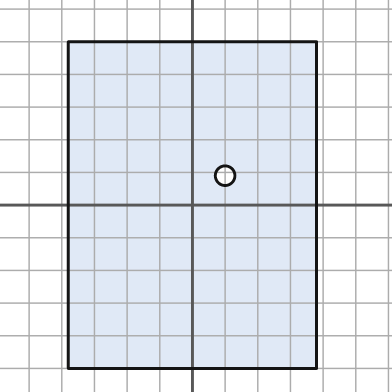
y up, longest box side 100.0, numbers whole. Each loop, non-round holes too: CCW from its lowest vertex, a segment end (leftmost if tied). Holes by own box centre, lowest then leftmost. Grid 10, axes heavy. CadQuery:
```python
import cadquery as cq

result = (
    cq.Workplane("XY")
    .moveTo(-38.0, -50.0)
    .lineTo(38.0, -50.0)
    .lineTo(38.0, 50.0)
    .lineTo(-38.0, 50.0)
    .close()
    .moveTo(10.0, 9.0)
    .circle(3.0)
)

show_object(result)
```